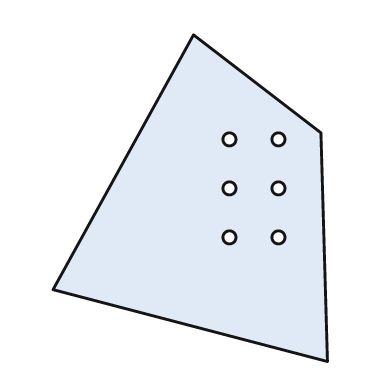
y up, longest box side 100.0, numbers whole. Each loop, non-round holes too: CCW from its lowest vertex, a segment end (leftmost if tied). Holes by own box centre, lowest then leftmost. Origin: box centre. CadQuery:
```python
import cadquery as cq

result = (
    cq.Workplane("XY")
    .moveTo(42.0, -50.0)
    .lineTo(40.0, 20.0)
    .lineTo(1.0, 50.0)
    .lineTo(-42.0, -28.0)
    .close()
    .moveTo(12.0, -12.0)
    .circle(2.0)
    .moveTo(27.0, -12.0)
    .circle(2.0)
    .moveTo(12.0, 3.0)
    .circle(2.0)
    .moveTo(27.0, 3.0)
    .circle(2.0)
    .moveTo(12.0, 18.0)
    .circle(2.0)
    .moveTo(27.0, 18.0)
    .circle(2.0)
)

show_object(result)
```